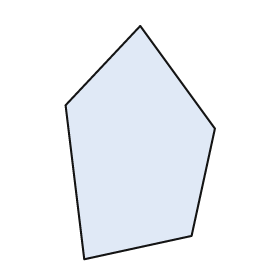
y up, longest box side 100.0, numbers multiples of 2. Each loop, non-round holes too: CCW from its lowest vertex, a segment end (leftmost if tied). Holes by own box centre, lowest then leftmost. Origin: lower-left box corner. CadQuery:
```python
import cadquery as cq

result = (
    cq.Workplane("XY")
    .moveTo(8.0, 0.0)
    .lineTo(54.0, 10.0)
    .lineTo(64.0, 56.0)
    .lineTo(32.0, 100.0)
    .lineTo(0.0, 66.0)
    .close()
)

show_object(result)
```